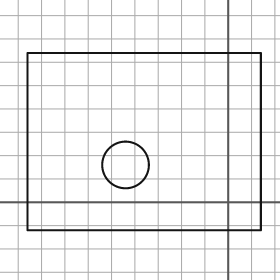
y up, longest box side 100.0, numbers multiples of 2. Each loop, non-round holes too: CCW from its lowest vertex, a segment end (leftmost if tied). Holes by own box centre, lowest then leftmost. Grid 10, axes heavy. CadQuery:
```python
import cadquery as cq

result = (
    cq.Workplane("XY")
    .moveTo(-86.0, -12.0)
    .lineTo(14.0, -12.0)
    .lineTo(14.0, 64.0)
    .lineTo(-86.0, 64.0)
    .close()
    .moveTo(-44.0, 16.0)
    .circle(10.0)
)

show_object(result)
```